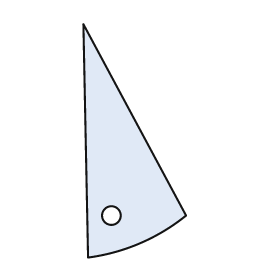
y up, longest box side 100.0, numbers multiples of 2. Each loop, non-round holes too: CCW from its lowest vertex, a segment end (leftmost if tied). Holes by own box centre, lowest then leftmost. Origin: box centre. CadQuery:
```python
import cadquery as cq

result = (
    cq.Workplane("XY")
    .moveTo(-20.0, -50.0)
    .threePointArc((2.0, -44.0), (22.0, -32.0))
    .lineTo(-22.0, 50.0)
    .close()
    .moveTo(-10.0, -32.0)
    .circle(4.0)
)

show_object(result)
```